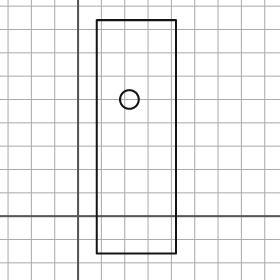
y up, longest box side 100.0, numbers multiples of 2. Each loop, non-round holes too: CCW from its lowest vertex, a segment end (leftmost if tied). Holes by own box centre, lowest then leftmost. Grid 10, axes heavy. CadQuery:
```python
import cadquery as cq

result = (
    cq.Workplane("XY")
    .moveTo(8.0, -16.0)
    .lineTo(42.0, -16.0)
    .lineTo(42.0, 84.0)
    .lineTo(8.0, 84.0)
    .close()
    .moveTo(22.0, 50.0)
    .circle(4.0)
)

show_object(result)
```